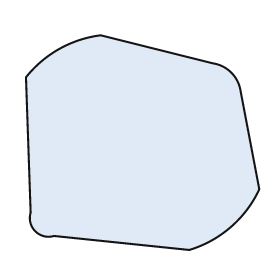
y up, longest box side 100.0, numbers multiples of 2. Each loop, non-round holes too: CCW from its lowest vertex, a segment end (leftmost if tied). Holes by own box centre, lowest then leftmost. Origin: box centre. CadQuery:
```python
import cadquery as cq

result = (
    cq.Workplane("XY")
    .moveTo(20.0, -46.0)
    .threePointArc((38.0, -36.0), (50.0, -20.0))
    .lineTo(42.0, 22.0)
    .threePointArc((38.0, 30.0), (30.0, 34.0))
    .lineTo(-18.0, 46.0)
    .threePointArc((-36.0, 40.0), (-50.0, 28.0))
    .lineTo(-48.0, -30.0)
    .threePointArc((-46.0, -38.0), (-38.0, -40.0))
    .close()
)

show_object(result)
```